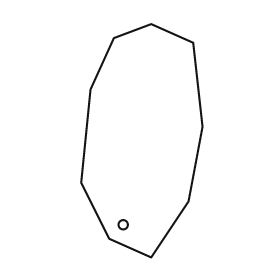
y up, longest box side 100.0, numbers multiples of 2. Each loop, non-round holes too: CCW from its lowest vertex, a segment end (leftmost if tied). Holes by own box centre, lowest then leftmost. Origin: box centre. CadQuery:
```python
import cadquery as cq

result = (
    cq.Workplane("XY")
    .moveTo(4.0, -50.0)
    .lineTo(20.0, -26.0)
    .lineTo(26.0, 6.0)
    .lineTo(22.0, 42.0)
    .lineTo(4.0, 50.0)
    .lineTo(-12.0, 44.0)
    .lineTo(-22.0, 22.0)
    .lineTo(-26.0, -18.0)
    .lineTo(-14.0, -42.0)
    .close()
    .moveTo(-8.0, -36.0)
    .circle(2.0)
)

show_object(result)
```